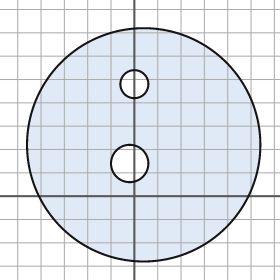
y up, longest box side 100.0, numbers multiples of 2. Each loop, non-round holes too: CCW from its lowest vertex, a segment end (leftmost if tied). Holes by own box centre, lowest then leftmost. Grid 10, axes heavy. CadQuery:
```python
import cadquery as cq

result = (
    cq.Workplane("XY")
    .moveTo(4.0, 22.0)
    .circle(50.0)
    .moveTo(-2.0, 14.0)
    .circle(8.0)
    .moveTo(0.0, 48.0)
    .circle(6.0)
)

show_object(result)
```